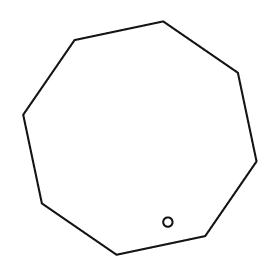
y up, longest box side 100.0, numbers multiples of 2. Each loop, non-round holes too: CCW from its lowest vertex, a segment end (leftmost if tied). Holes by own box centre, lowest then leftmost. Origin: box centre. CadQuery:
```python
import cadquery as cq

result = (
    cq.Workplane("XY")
    .moveTo(-10.0, -50.0)
    .lineTo(28.0, -42.0)
    .lineTo(50.0, -10.0)
    .lineTo(42.0, 28.0)
    .lineTo(10.0, 50.0)
    .lineTo(-28.0, 42.0)
    .lineTo(-50.0, 10.0)
    .lineTo(-42.0, -28.0)
    .close()
    .moveTo(12.0, -36.0)
    .circle(2.0)
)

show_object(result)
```